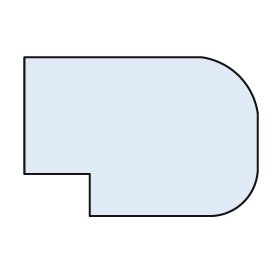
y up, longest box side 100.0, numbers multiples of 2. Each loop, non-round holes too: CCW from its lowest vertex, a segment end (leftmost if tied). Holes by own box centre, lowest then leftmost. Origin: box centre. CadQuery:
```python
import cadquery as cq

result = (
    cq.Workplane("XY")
    .moveTo(-22.0, -34.0)
    .lineTo(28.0, -34.0)
    .threePointArc((44.0, -28.0), (50.0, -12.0))
    .lineTo(50.0, 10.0)
    .threePointArc((42.0, 26.0), (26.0, 34.0))
    .lineTo(-50.0, 34.0)
    .lineTo(-50.0, -16.0)
    .lineTo(-22.0, -16.0)
    .close()
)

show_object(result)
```